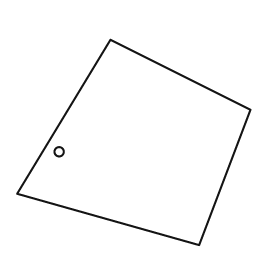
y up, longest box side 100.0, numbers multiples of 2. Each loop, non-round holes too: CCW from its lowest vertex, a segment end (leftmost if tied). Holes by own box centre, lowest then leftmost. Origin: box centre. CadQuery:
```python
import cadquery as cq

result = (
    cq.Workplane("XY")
    .moveTo(28.0, -44.0)
    .lineTo(50.0, 14.0)
    .lineTo(-10.0, 44.0)
    .lineTo(-50.0, -22.0)
    .close()
    .moveTo(-32.0, -4.0)
    .circle(2.0)
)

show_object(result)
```